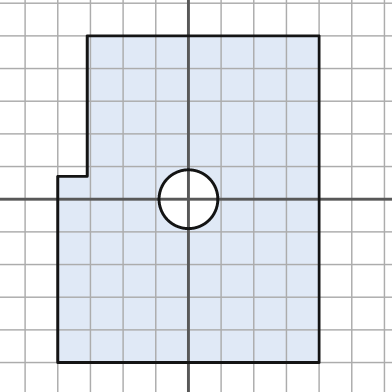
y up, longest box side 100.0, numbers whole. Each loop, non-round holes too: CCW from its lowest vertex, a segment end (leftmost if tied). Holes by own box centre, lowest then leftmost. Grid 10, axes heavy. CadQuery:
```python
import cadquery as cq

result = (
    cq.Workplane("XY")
    .moveTo(-40.0, -50.0)
    .lineTo(40.0, -50.0)
    .lineTo(40.0, 50.0)
    .lineTo(-31.0, 50.0)
    .lineTo(-31.0, 7.0)
    .lineTo(-40.0, 7.0)
    .close()
    .moveTo(0.0, 0.0)
    .circle(9.0)
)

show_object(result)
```